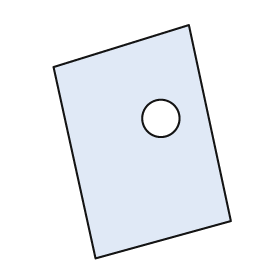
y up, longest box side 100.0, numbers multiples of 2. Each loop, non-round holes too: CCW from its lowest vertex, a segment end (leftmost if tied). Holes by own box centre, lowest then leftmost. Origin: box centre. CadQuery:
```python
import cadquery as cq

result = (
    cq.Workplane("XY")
    .moveTo(-20.0, -50.0)
    .lineTo(38.0, -34.0)
    .lineTo(20.0, 50.0)
    .lineTo(-38.0, 32.0)
    .close()
    .moveTo(8.0, 10.0)
    .circle(8.0)
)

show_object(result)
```